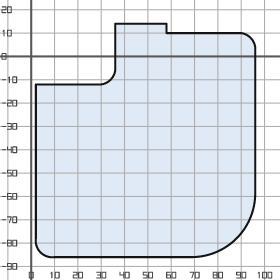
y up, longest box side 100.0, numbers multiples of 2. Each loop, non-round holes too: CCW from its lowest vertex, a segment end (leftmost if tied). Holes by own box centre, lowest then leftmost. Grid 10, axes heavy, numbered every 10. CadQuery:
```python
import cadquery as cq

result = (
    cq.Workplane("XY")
    .moveTo(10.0, -86.0)
    .lineTo(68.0, -86.0)
    .threePointArc((88.0, -78.0), (96.0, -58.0))
    .lineTo(96.0, 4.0)
    .threePointArc((94.0, 8.0), (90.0, 10.0))
    .lineTo(58.0, 10.0)
    .lineTo(58.0, 14.0)
    .lineTo(36.0, 14.0)
    .lineTo(36.0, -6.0)
    .threePointArc((34.0, -10.0), (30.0, -12.0))
    .lineTo(2.0, -12.0)
    .lineTo(2.0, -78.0)
    .threePointArc((4.0, -84.0), (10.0, -86.0))
    .close()
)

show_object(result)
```